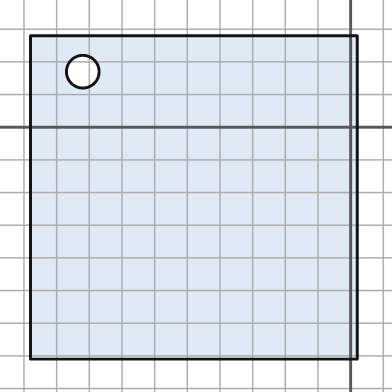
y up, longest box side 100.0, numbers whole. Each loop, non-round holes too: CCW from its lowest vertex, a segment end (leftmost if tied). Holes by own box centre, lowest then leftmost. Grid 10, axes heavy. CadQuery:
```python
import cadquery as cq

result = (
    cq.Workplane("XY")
    .moveTo(-98.0, -71.0)
    .lineTo(2.0, -71.0)
    .lineTo(2.0, 28.0)
    .lineTo(-98.0, 28.0)
    .close()
    .moveTo(-82.0, 17.0)
    .circle(5.0)
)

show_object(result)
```